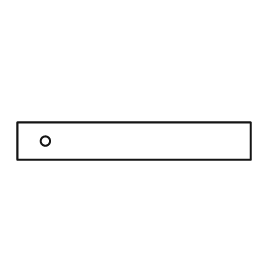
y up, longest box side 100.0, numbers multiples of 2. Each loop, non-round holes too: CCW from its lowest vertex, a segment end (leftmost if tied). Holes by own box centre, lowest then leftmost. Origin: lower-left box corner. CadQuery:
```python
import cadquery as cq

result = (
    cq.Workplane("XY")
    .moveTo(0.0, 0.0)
    .lineTo(100.0, 0.0)
    .lineTo(100.0, 16.0)
    .lineTo(0.0, 16.0)
    .close()
    .moveTo(12.0, 8.0)
    .circle(2.0)
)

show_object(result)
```